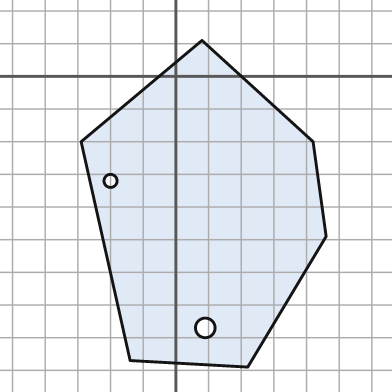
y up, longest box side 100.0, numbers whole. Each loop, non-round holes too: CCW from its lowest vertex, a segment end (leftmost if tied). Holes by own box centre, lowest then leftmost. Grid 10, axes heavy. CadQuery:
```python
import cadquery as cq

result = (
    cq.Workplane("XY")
    .moveTo(22.0, -89.0)
    .lineTo(46.0, -49.0)
    .lineTo(42.0, -20.0)
    .lineTo(8.0, 11.0)
    .lineTo(-29.0, -20.0)
    .lineTo(-14.0, -87.0)
    .close()
    .moveTo(9.0, -77.0)
    .circle(3.0)
    .moveTo(-20.0, -32.0)
    .circle(2.0)
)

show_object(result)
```